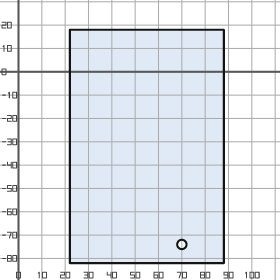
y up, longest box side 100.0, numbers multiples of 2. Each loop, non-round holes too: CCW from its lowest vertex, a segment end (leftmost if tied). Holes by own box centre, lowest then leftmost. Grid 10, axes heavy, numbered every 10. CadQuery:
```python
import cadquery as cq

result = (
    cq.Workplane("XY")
    .moveTo(22.0, -82.0)
    .lineTo(88.0, -82.0)
    .lineTo(88.0, 18.0)
    .lineTo(22.0, 18.0)
    .close()
    .moveTo(70.0, -74.0)
    .circle(2.0)
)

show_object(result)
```